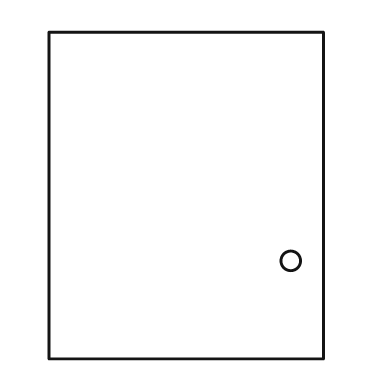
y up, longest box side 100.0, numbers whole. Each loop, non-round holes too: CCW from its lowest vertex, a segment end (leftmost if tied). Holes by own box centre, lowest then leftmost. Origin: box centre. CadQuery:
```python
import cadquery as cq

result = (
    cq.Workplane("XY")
    .moveTo(-42.0, -50.0)
    .lineTo(42.0, -50.0)
    .lineTo(42.0, 50.0)
    .lineTo(-42.0, 50.0)
    .close()
    .moveTo(32.0, -20.0)
    .circle(3.0)
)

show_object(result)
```